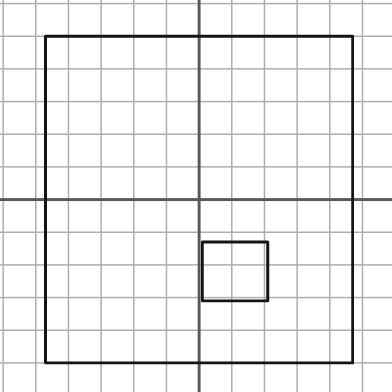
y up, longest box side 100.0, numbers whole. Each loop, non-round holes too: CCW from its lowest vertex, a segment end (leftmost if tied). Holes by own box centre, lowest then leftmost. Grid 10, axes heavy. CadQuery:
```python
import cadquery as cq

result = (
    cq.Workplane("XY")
    .moveTo(-47.0, -50.0)
    .lineTo(47.0, -50.0)
    .lineTo(47.0, 50.0)
    .lineTo(-47.0, 50.0)
    .close()
    .moveTo(1.0, -31.0)
    .lineTo(21.0, -31.0)
    .lineTo(21.0, -13.0)
    .lineTo(1.0, -13.0)
    .close()
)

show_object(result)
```